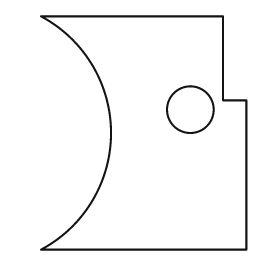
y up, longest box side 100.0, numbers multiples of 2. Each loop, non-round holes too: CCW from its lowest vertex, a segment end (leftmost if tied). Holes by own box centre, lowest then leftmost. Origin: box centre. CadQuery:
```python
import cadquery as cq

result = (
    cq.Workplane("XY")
    .moveTo(-44.0, -50.0)
    .lineTo(44.0, -50.0)
    .lineTo(44.0, 14.0)
    .lineTo(34.0, 14.0)
    .lineTo(34.0, 50.0)
    .lineTo(-44.0, 50.0)
    .threePointArc((-14.0, 0.0), (-44.0, -50.0))
    .close()
    .moveTo(20.0, 10.0)
    .circle(10.0)
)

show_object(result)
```